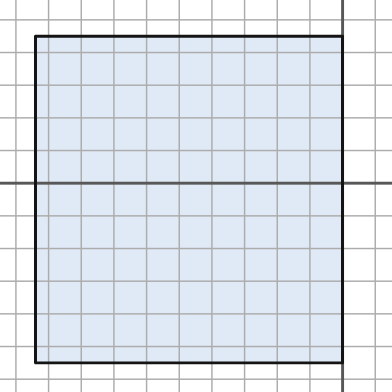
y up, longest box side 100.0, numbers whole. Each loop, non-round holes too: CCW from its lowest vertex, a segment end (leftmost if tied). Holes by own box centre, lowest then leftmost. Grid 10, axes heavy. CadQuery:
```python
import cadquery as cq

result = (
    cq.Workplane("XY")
    .moveTo(-94.0, -55.0)
    .lineTo(0.0, -55.0)
    .lineTo(0.0, 45.0)
    .lineTo(-94.0, 45.0)
    .close()
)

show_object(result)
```